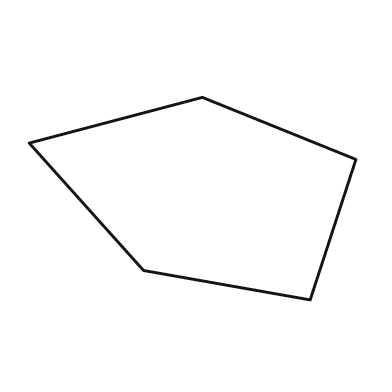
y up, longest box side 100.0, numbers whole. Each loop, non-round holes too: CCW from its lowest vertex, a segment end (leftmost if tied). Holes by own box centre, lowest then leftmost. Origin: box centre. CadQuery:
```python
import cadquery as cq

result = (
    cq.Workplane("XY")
    .moveTo(36.0, -31.0)
    .lineTo(50.0, 12.0)
    .lineTo(3.0, 31.0)
    .lineTo(-50.0, 17.0)
    .lineTo(-15.0, -22.0)
    .close()
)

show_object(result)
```